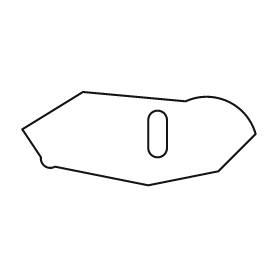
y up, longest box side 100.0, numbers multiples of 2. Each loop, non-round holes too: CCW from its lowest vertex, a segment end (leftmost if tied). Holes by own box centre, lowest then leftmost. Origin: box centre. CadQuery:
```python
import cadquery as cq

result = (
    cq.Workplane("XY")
    .moveTo(4.0, -20.0)
    .lineTo(34.0, -14.0)
    .lineTo(50.0, 2.0)
    .threePointArc((38.0, 16.0), (20.0, 16.0))
    .lineTo(-24.0, 20.0)
    .lineTo(-50.0, 4.0)
    .lineTo(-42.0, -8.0)
    .threePointArc((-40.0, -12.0), (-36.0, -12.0))
    .close()
    .moveTo(4.0, -4.0)
    .threePointArc((8.0, -8.0), (12.0, -4.0))
    .lineTo(12.0, 8.0)
    .threePointArc((8.0, 12.0), (4.0, 8.0))
    .close()
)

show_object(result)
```